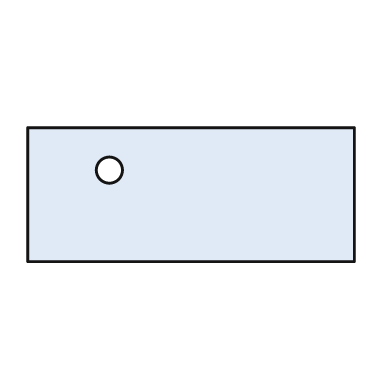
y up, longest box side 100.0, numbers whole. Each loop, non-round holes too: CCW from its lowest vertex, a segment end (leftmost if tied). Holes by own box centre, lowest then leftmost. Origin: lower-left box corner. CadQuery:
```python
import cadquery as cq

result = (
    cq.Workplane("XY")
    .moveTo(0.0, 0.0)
    .lineTo(100.0, 0.0)
    .lineTo(100.0, 41.0)
    .lineTo(0.0, 41.0)
    .close()
    .moveTo(25.0, 28.0)
    .circle(4.0)
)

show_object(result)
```